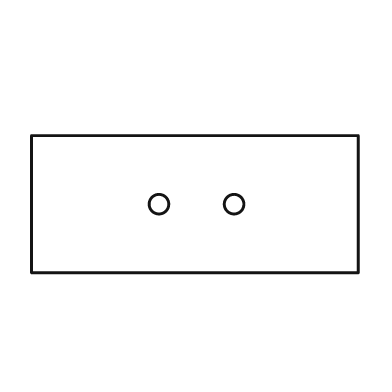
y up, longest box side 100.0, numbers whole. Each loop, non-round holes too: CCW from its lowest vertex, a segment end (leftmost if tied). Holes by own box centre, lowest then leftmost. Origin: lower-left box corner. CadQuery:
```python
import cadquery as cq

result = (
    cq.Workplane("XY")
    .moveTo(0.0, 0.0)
    .lineTo(100.0, 0.0)
    .lineTo(100.0, 42.0)
    .lineTo(0.0, 42.0)
    .close()
    .moveTo(39.0, 21.0)
    .circle(3.0)
    .moveTo(62.0, 21.0)
    .circle(3.0)
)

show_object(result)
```